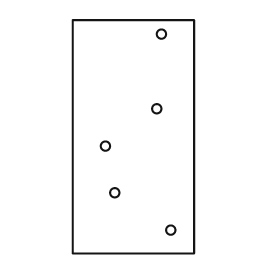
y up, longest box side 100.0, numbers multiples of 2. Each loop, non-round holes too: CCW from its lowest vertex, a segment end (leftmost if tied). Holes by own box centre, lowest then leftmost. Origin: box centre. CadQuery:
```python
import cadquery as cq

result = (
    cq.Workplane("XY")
    .moveTo(-26.0, -50.0)
    .lineTo(26.0, -50.0)
    .lineTo(26.0, 50.0)
    .lineTo(-26.0, 50.0)
    .close()
    .moveTo(16.0, -40.0)
    .circle(2.0)
    .moveTo(-8.0, -24.0)
    .circle(2.0)
    .moveTo(-12.0, -4.0)
    .circle(2.0)
    .moveTo(10.0, 12.0)
    .circle(2.0)
    .moveTo(12.0, 44.0)
    .circle(2.0)
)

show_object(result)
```